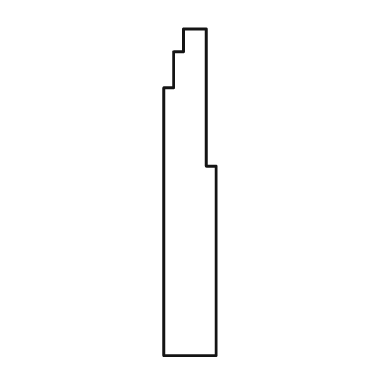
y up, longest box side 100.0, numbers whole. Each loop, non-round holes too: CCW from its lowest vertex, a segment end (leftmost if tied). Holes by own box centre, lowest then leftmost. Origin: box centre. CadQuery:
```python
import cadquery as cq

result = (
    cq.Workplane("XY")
    .moveTo(-8.0, -50.0)
    .lineTo(8.0, -50.0)
    .lineTo(8.0, 8.0)
    .lineTo(5.0, 8.0)
    .lineTo(5.0, 50.0)
    .lineTo(-2.0, 50.0)
    .lineTo(-2.0, 43.0)
    .lineTo(-5.0, 43.0)
    .lineTo(-5.0, 32.0)
    .lineTo(-8.0, 32.0)
    .close()
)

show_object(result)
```